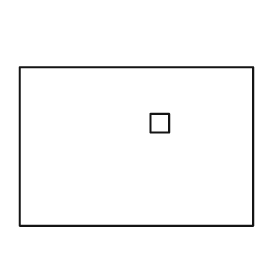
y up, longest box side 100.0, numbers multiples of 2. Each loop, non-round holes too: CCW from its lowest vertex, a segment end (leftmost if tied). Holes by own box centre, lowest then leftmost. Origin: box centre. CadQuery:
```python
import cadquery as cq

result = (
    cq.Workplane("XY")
    .moveTo(-50.0, -34.0)
    .lineTo(50.0, -34.0)
    .lineTo(50.0, 34.0)
    .lineTo(-50.0, 34.0)
    .close()
    .moveTo(6.0, 6.0)
    .lineTo(14.0, 6.0)
    .lineTo(14.0, 14.0)
    .lineTo(6.0, 14.0)
    .close()
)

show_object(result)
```